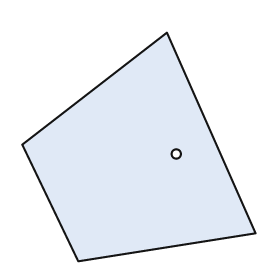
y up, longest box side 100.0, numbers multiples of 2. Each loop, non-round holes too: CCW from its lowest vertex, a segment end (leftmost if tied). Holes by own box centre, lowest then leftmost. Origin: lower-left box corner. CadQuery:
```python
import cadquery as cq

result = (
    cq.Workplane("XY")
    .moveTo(24.0, 0.0)
    .lineTo(100.0, 12.0)
    .lineTo(62.0, 98.0)
    .lineTo(0.0, 50.0)
    .close()
    .moveTo(66.0, 46.0)
    .circle(2.0)
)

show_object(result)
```